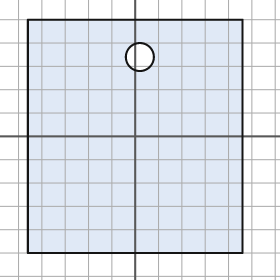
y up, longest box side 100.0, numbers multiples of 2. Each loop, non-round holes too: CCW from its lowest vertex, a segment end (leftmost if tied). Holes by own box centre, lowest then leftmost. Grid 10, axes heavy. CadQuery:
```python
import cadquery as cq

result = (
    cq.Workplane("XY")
    .moveTo(-46.0, -50.0)
    .lineTo(46.0, -50.0)
    .lineTo(46.0, 50.0)
    .lineTo(-46.0, 50.0)
    .close()
    .moveTo(2.0, 34.0)
    .circle(6.0)
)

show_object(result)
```